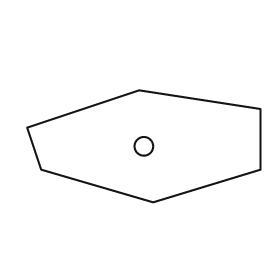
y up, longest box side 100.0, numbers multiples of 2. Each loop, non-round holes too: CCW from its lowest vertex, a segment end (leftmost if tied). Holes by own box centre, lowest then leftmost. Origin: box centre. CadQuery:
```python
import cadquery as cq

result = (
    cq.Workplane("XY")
    .moveTo(4.0, -24.0)
    .lineTo(50.0, -10.0)
    .lineTo(50.0, 16.0)
    .lineTo(-2.0, 24.0)
    .lineTo(-50.0, 8.0)
    .lineTo(-44.0, -10.0)
    .close()
    .moveTo(0.0, 0.0)
    .circle(4.0)
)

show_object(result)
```